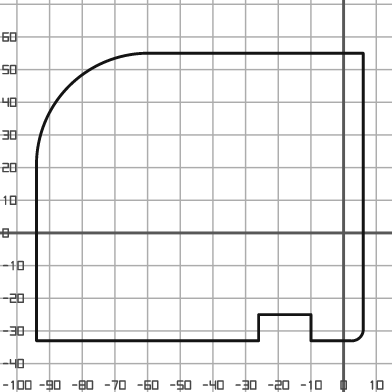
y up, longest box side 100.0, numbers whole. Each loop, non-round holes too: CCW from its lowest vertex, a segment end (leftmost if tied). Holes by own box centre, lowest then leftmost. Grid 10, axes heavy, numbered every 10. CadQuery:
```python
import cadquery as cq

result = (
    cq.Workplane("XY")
    .moveTo(-94.0, -33.0)
    .lineTo(-26.0, -33.0)
    .lineTo(-26.0, -25.0)
    .lineTo(-10.0, -25.0)
    .lineTo(-10.0, -33.0)
    .lineTo(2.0, -33.0)
    .threePointArc((5.0, -32.0), (6.0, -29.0))
    .lineTo(6.0, 55.0)
    .lineTo(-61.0, 55.0)
    .threePointArc((-84.0, 45.0), (-94.0, 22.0))
    .close()
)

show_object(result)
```